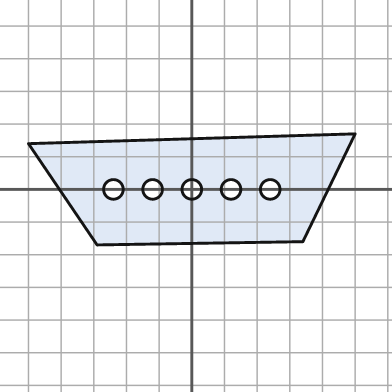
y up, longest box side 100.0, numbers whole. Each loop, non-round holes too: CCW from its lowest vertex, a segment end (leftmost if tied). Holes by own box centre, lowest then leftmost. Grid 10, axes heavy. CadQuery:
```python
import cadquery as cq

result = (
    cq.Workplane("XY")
    .moveTo(-29.0, -17.0)
    .lineTo(34.0, -16.0)
    .lineTo(50.0, 17.0)
    .lineTo(-50.0, 14.0)
    .close()
    .moveTo(-24.0, 0.0)
    .circle(3.0)
    .moveTo(-12.0, 0.0)
    .circle(3.0)
    .moveTo(0.0, 0.0)
    .circle(3.0)
    .moveTo(12.0, 0.0)
    .circle(3.0)
    .moveTo(24.0, 0.0)
    .circle(3.0)
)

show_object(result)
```